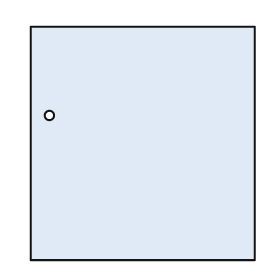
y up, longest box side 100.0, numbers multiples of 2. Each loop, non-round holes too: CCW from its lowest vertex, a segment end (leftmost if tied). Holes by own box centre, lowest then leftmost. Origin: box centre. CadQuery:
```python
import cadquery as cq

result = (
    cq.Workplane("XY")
    .moveTo(-48.0, -50.0)
    .lineTo(48.0, -50.0)
    .lineTo(48.0, 50.0)
    .lineTo(-48.0, 50.0)
    .close()
    .moveTo(-40.0, 12.0)
    .circle(2.0)
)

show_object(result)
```